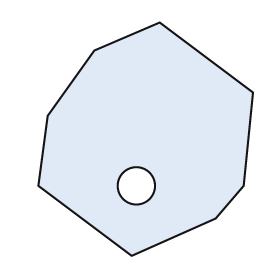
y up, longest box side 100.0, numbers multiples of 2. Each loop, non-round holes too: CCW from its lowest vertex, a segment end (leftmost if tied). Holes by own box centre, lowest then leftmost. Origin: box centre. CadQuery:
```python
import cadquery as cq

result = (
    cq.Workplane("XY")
    .moveTo(-6.0, -50.0)
    .lineTo(30.0, -34.0)
    .lineTo(42.0, -20.0)
    .lineTo(46.0, 20.0)
    .lineTo(6.0, 50.0)
    .lineTo(-22.0, 38.0)
    .lineTo(-42.0, 10.0)
    .lineTo(-46.0, -20.0)
    .close()
    .moveTo(-4.0, -20.0)
    .circle(8.0)
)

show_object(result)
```